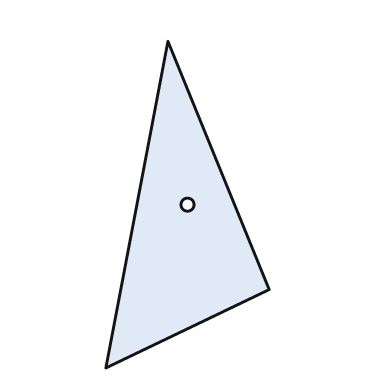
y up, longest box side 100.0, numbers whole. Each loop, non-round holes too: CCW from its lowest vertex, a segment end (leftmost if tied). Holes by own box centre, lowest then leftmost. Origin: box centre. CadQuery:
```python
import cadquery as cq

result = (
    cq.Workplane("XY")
    .moveTo(-25.0, -50.0)
    .lineTo(25.0, -26.0)
    .lineTo(-6.0, 50.0)
    .close()
    .moveTo(0.0, 0.0)
    .circle(2.0)
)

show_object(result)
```